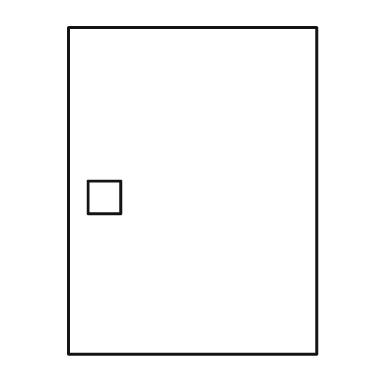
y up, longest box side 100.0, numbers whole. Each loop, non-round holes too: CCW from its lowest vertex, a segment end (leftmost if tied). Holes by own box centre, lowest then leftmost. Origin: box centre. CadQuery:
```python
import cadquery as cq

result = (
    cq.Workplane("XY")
    .moveTo(-38.0, -50.0)
    .lineTo(38.0, -50.0)
    .lineTo(38.0, 50.0)
    .lineTo(-38.0, 50.0)
    .close()
    .moveTo(-32.0, -7.0)
    .lineTo(-22.0, -7.0)
    .lineTo(-22.0, 3.0)
    .lineTo(-32.0, 3.0)
    .close()
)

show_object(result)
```